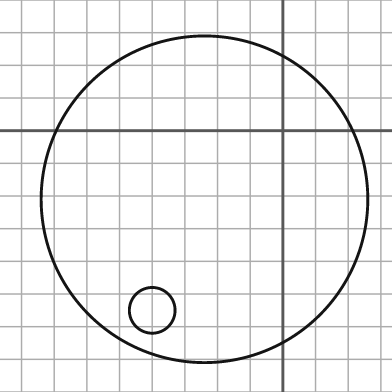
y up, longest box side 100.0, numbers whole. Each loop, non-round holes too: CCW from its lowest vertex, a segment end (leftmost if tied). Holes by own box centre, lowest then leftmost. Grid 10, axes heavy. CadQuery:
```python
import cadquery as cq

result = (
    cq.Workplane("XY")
    .moveTo(-24.0, -21.0)
    .circle(50.0)
    .moveTo(-40.0, -55.0)
    .circle(7.0)
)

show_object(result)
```